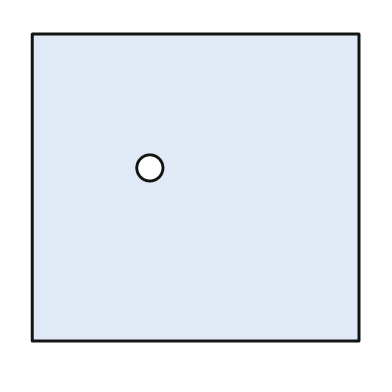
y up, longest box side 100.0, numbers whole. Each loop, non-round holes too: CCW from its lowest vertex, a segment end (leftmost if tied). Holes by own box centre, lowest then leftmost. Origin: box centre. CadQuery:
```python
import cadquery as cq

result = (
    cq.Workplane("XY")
    .moveTo(-50.0, -47.0)
    .lineTo(50.0, -47.0)
    .lineTo(50.0, 47.0)
    .lineTo(-50.0, 47.0)
    .close()
    .moveTo(-14.0, 6.0)
    .circle(4.0)
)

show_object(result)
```